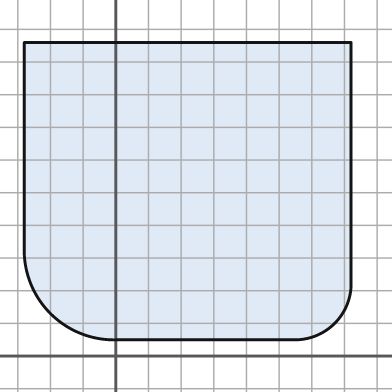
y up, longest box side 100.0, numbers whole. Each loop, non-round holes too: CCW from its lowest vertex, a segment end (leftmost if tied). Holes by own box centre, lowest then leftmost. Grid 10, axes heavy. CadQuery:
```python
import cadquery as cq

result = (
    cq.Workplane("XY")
    .moveTo(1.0, 5.0)
    .lineTo(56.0, 5.0)
    .threePointArc((67.0, 10.0), (72.0, 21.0))
    .lineTo(72.0, 96.0)
    .lineTo(-28.0, 96.0)
    .lineTo(-28.0, 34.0)
    .threePointArc((-20.0, 13.0), (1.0, 5.0))
    .close()
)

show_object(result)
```